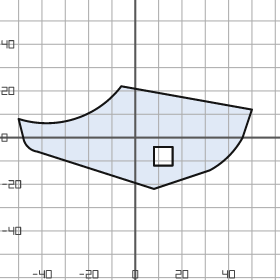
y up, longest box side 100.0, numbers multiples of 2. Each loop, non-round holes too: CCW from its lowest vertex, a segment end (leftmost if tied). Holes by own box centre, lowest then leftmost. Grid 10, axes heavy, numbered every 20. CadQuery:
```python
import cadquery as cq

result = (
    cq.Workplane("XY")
    .moveTo(8.0, -22.0)
    .lineTo(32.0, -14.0)
    .threePointArc((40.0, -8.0), (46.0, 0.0))
    .lineTo(50.0, 12.0)
    .lineTo(-6.0, 22.0)
    .threePointArc((-26.0, 8.0), (-50.0, 8.0))
    .lineTo(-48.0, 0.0)
    .threePointArc((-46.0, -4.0), (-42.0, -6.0))
    .close()
    .moveTo(8.0, -12.0)
    .lineTo(16.0, -12.0)
    .lineTo(16.0, -4.0)
    .lineTo(8.0, -4.0)
    .close()
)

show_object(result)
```